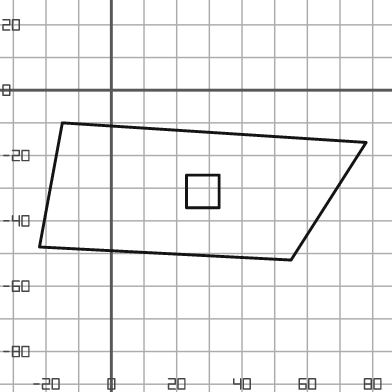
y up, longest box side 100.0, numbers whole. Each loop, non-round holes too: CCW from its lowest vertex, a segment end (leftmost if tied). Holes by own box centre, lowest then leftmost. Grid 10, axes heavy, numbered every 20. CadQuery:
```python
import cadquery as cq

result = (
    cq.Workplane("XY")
    .moveTo(55.0, -52.0)
    .lineTo(78.0, -16.0)
    .lineTo(-15.0, -10.0)
    .lineTo(-22.0, -48.0)
    .close()
    .moveTo(23.0, -36.0)
    .lineTo(33.0, -36.0)
    .lineTo(33.0, -26.0)
    .lineTo(23.0, -26.0)
    .close()
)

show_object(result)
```